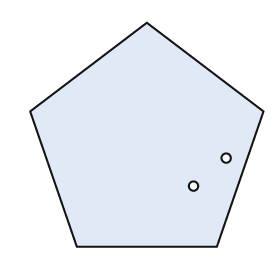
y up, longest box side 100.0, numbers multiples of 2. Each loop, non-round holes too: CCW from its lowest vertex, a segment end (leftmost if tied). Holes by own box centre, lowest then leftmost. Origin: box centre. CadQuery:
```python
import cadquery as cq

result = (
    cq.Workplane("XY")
    .moveTo(-30.0, -48.0)
    .lineTo(30.0, -48.0)
    .lineTo(50.0, 10.0)
    .lineTo(0.0, 48.0)
    .lineTo(-50.0, 10.0)
    .close()
    .moveTo(20.0, -22.0)
    .circle(2.0)
    .moveTo(34.0, -10.0)
    .circle(2.0)
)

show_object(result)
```